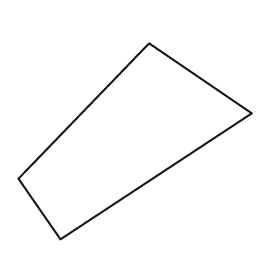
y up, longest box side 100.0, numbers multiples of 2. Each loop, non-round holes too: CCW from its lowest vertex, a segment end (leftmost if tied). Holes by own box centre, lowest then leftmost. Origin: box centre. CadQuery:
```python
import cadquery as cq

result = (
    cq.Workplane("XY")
    .moveTo(-32.0, -42.0)
    .lineTo(50.0, 12.0)
    .lineTo(6.0, 42.0)
    .lineTo(-50.0, -16.0)
    .close()
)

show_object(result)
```